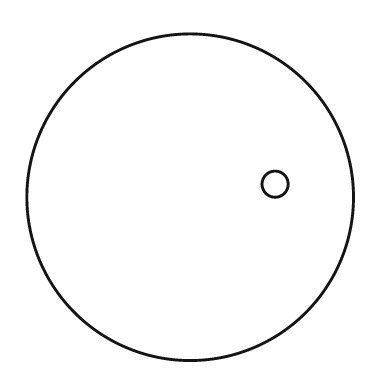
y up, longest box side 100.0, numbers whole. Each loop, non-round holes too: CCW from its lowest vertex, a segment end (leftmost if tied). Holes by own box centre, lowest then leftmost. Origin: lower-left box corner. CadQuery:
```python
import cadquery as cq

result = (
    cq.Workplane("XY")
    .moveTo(50.0, 50.0)
    .circle(50.0)
    .moveTo(76.0, 54.0)
    .circle(4.0)
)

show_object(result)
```